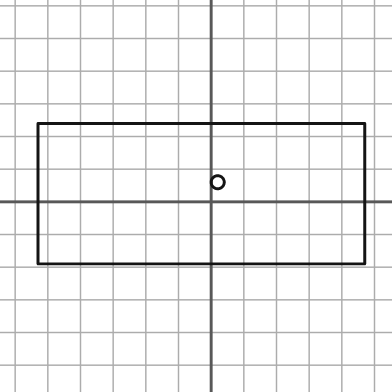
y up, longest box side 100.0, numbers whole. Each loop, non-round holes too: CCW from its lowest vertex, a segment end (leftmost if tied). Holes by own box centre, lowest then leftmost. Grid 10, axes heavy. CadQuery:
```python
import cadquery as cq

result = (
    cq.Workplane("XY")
    .moveTo(-53.0, -19.0)
    .lineTo(47.0, -19.0)
    .lineTo(47.0, 24.0)
    .lineTo(-53.0, 24.0)
    .close()
    .moveTo(2.0, 6.0)
    .circle(2.0)
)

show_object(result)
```